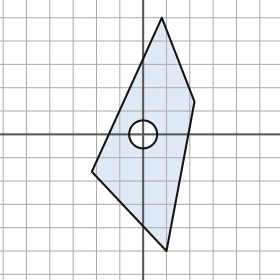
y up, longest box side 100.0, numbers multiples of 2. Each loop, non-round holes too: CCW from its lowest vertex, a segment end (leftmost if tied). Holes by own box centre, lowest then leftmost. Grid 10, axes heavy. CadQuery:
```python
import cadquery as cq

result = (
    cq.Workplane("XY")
    .moveTo(10.0, -50.0)
    .lineTo(22.0, 14.0)
    .lineTo(8.0, 50.0)
    .lineTo(-22.0, -16.0)
    .close()
    .moveTo(0.0, 0.0)
    .circle(6.0)
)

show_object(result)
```